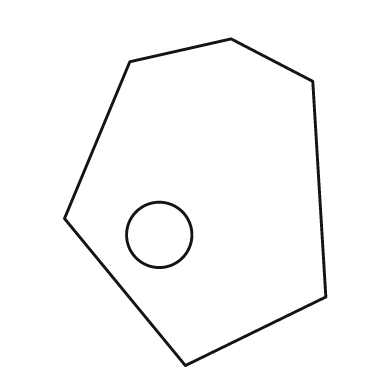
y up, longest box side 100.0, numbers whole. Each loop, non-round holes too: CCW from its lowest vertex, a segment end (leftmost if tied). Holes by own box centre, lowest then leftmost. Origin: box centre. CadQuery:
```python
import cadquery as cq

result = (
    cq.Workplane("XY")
    .moveTo(-3.0, -50.0)
    .lineTo(40.0, -29.0)
    .lineTo(36.0, 37.0)
    .lineTo(11.0, 50.0)
    .lineTo(-20.0, 43.0)
    .lineTo(-40.0, -5.0)
    .close()
    .moveTo(-11.0, -10.0)
    .circle(10.0)
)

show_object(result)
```